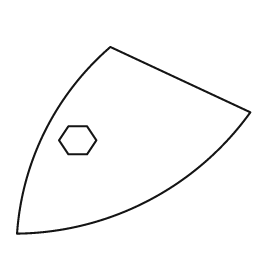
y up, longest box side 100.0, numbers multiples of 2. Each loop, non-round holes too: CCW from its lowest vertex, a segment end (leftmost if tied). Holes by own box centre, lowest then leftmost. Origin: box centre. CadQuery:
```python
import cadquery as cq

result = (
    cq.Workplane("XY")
    .moveTo(-50.0, -40.0)
    .threePointArc((6.0, -26.0), (50.0, 12.0))
    .lineTo(-10.0, 40.0)
    .threePointArc((-38.0, 4.0), (-50.0, -40.0))
    .close()
    .moveTo(-28.0, -6.0)
    .lineTo(-20.0, -6.0)
    .lineTo(-16.0, 0.0)
    .lineTo(-20.0, 6.0)
    .lineTo(-28.0, 6.0)
    .lineTo(-32.0, 0.0)
    .close()
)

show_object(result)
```